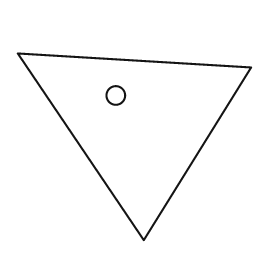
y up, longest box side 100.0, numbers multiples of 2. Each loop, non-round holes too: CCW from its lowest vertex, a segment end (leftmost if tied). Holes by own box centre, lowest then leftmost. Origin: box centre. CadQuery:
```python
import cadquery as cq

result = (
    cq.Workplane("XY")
    .moveTo(4.0, -40.0)
    .lineTo(50.0, 34.0)
    .lineTo(-50.0, 40.0)
    .close()
    .moveTo(-8.0, 22.0)
    .circle(4.0)
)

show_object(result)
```